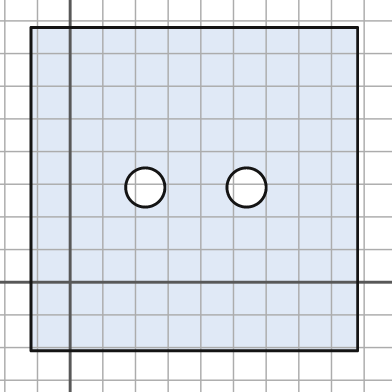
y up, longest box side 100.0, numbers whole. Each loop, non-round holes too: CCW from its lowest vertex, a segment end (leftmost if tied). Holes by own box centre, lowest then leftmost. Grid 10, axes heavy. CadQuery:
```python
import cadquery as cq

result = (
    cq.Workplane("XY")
    .moveTo(-12.0, -21.0)
    .lineTo(88.0, -21.0)
    .lineTo(88.0, 78.0)
    .lineTo(-12.0, 78.0)
    .close()
    .moveTo(23.0, 29.0)
    .circle(6.0)
    .moveTo(54.0, 29.0)
    .circle(6.0)
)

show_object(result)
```